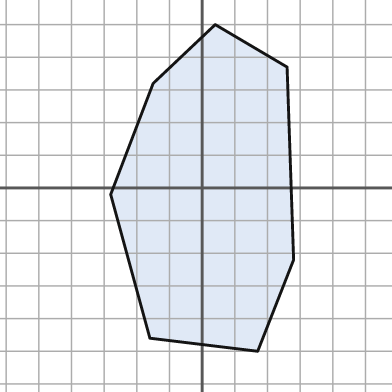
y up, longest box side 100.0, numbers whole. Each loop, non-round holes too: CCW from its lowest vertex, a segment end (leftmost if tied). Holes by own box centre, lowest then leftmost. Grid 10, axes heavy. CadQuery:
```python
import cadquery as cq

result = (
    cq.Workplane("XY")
    .moveTo(17.0, -50.0)
    .lineTo(28.0, -22.0)
    .lineTo(26.0, 37.0)
    .lineTo(4.0, 50.0)
    .lineTo(-15.0, 32.0)
    .lineTo(-28.0, -2.0)
    .lineTo(-16.0, -46.0)
    .close()
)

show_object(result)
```